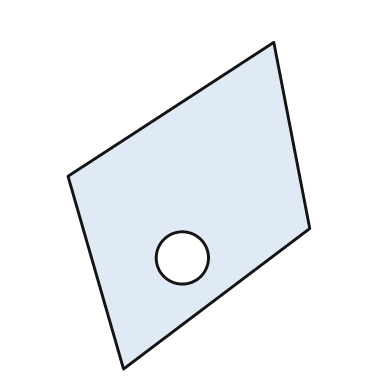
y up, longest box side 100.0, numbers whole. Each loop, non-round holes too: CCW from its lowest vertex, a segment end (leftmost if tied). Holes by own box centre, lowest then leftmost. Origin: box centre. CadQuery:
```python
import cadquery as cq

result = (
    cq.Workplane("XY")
    .moveTo(-20.0, -50.0)
    .lineTo(37.0, -7.0)
    .lineTo(26.0, 50.0)
    .lineTo(-37.0, 9.0)
    .close()
    .moveTo(-2.0, -16.0)
    .circle(8.0)
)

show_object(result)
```